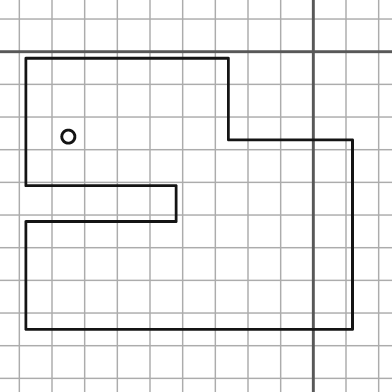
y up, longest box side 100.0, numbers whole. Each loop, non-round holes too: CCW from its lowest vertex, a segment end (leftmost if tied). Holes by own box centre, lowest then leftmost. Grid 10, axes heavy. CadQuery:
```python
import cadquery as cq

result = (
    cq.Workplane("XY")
    .moveTo(-88.0, -85.0)
    .lineTo(12.0, -85.0)
    .lineTo(12.0, -27.0)
    .lineTo(-26.0, -27.0)
    .lineTo(-26.0, -2.0)
    .lineTo(-88.0, -2.0)
    .lineTo(-88.0, -41.0)
    .lineTo(-42.0, -41.0)
    .lineTo(-42.0, -52.0)
    .lineTo(-88.0, -52.0)
    .close()
    .moveTo(-75.0, -26.0)
    .circle(2.0)
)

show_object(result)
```